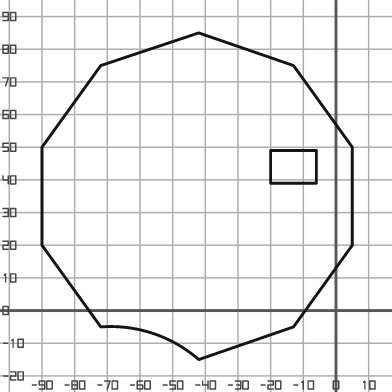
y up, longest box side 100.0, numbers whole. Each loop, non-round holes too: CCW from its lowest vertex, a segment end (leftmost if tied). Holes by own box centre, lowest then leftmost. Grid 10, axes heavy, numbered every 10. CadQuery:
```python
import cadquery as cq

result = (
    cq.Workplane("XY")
    .moveTo(-42.0, -15.0)
    .lineTo(-13.0, -5.0)
    .lineTo(5.0, 20.0)
    .lineTo(5.0, 50.0)
    .lineTo(-13.0, 75.0)
    .lineTo(-42.0, 85.0)
    .lineTo(-72.0, 75.0)
    .lineTo(-90.0, 50.0)
    .lineTo(-90.0, 20.0)
    .lineTo(-72.0, -5.0)
    .threePointArc((-56.0, -7.0), (-42.0, -15.0))
    .close()
    .moveTo(-20.0, 39.0)
    .lineTo(-6.0, 39.0)
    .lineTo(-6.0, 49.0)
    .lineTo(-20.0, 49.0)
    .close()
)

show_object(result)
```